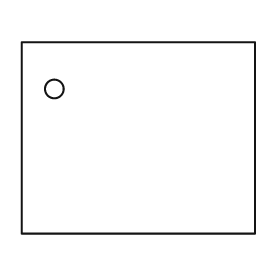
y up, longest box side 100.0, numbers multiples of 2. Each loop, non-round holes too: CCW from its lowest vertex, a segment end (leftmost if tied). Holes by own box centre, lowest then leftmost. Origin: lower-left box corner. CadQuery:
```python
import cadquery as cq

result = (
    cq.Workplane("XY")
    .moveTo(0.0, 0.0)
    .lineTo(100.0, 0.0)
    .lineTo(100.0, 82.0)
    .lineTo(0.0, 82.0)
    .close()
    .moveTo(14.0, 62.0)
    .circle(4.0)
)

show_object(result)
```